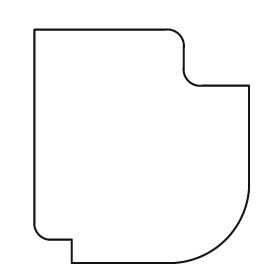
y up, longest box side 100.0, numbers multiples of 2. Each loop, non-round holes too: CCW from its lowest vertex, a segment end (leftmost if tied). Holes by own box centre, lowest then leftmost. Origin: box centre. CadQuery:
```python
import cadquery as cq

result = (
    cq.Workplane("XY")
    .moveTo(-30.0, -50.0)
    .lineTo(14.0, -50.0)
    .threePointArc((36.0, -40.0), (46.0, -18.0))
    .lineTo(46.0, 26.0)
    .lineTo(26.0, 26.0)
    .threePointArc((20.0, 28.0), (18.0, 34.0))
    .lineTo(18.0, 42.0)
    .threePointArc((16.0, 48.0), (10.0, 50.0))
    .lineTo(-46.0, 50.0)
    .lineTo(-46.0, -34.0)
    .threePointArc((-44.0, -38.0), (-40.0, -40.0))
    .lineTo(-30.0, -40.0)
    .close()
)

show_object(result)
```